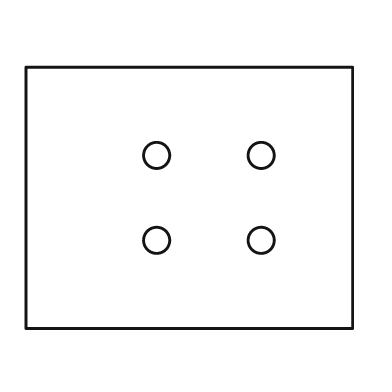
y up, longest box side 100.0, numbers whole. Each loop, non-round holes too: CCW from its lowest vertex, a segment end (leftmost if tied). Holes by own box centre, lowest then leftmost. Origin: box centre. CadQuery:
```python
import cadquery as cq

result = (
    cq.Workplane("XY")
    .moveTo(-50.0, -40.0)
    .lineTo(50.0, -40.0)
    .lineTo(50.0, 40.0)
    .lineTo(-50.0, 40.0)
    .close()
    .moveTo(-10.0, -13.0)
    .circle(4.0)
    .moveTo(22.0, -13.0)
    .circle(4.0)
    .moveTo(-10.0, 13.0)
    .circle(4.0)
    .moveTo(22.0, 13.0)
    .circle(4.0)
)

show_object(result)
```